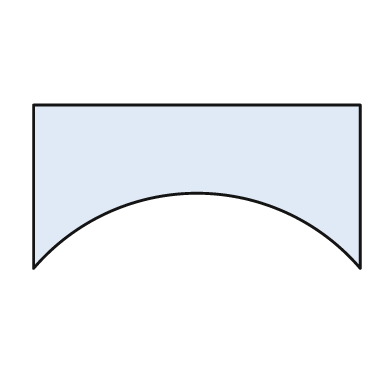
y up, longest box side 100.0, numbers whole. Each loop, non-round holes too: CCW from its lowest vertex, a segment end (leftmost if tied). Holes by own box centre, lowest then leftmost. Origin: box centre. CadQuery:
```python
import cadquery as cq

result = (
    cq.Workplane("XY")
    .moveTo(-50.0, -25.0)
    .threePointArc((0.0, -2.0), (50.0, -25.0))
    .lineTo(50.0, 25.0)
    .lineTo(-50.0, 25.0)
    .close()
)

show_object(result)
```